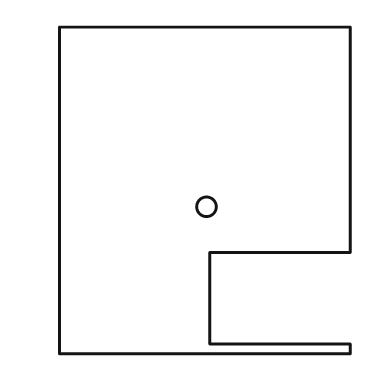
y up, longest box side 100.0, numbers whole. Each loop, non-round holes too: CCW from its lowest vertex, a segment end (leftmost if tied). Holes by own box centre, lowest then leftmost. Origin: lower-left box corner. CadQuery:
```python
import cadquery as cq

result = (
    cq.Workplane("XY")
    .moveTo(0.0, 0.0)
    .lineTo(89.0, 0.0)
    .lineTo(89.0, 3.0)
    .lineTo(46.0, 3.0)
    .lineTo(46.0, 31.0)
    .lineTo(89.0, 31.0)
    .lineTo(89.0, 100.0)
    .lineTo(0.0, 100.0)
    .close()
    .moveTo(45.0, 45.0)
    .circle(3.0)
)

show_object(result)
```